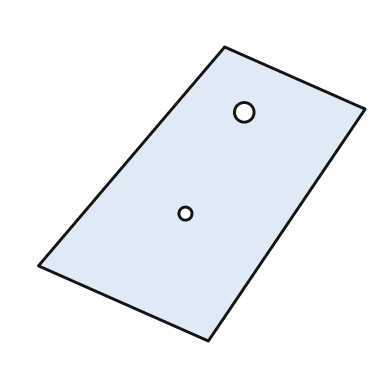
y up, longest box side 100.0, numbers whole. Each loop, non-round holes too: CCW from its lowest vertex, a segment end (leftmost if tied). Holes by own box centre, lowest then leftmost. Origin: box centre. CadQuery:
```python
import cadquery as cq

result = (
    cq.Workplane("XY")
    .moveTo(2.0, -45.0)
    .lineTo(50.0, 26.0)
    .lineTo(7.0, 45.0)
    .lineTo(-50.0, -22.0)
    .close()
    .moveTo(-5.0, -6.0)
    .circle(2.0)
    .moveTo(13.0, 25.0)
    .circle(3.0)
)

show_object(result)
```